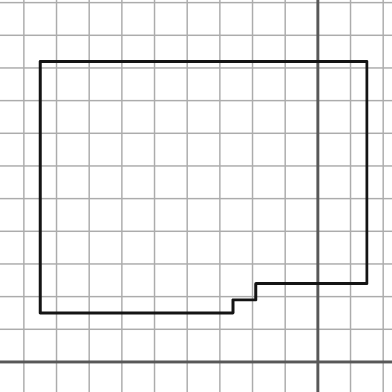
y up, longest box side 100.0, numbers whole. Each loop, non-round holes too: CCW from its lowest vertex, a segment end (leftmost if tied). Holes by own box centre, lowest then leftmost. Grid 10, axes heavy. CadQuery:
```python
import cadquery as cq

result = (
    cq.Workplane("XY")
    .moveTo(-85.0, 15.0)
    .lineTo(-26.0, 15.0)
    .lineTo(-26.0, 19.0)
    .lineTo(-19.0, 19.0)
    .lineTo(-19.0, 24.0)
    .lineTo(15.0, 24.0)
    .lineTo(15.0, 92.0)
    .lineTo(-85.0, 92.0)
    .close()
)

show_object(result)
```